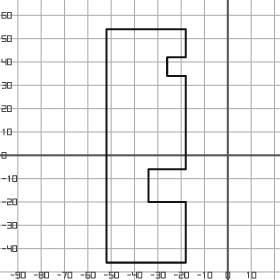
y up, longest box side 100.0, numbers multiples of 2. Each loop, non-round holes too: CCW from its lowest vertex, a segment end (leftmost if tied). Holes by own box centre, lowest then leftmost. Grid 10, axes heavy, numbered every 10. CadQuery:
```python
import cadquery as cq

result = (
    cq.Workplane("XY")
    .moveTo(-52.0, -46.0)
    .lineTo(-18.0, -46.0)
    .lineTo(-18.0, -20.0)
    .lineTo(-34.0, -20.0)
    .lineTo(-34.0, -6.0)
    .lineTo(-18.0, -6.0)
    .lineTo(-18.0, 34.0)
    .lineTo(-26.0, 34.0)
    .lineTo(-26.0, 42.0)
    .lineTo(-18.0, 42.0)
    .lineTo(-18.0, 54.0)
    .lineTo(-52.0, 54.0)
    .close()
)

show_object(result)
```